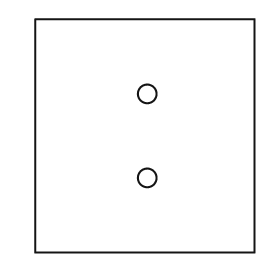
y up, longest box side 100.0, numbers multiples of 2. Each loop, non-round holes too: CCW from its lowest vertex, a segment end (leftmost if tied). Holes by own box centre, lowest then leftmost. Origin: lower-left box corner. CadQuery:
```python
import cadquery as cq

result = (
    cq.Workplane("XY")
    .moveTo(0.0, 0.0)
    .lineTo(94.0, 0.0)
    .lineTo(94.0, 100.0)
    .lineTo(0.0, 100.0)
    .close()
    .moveTo(48.0, 32.0)
    .circle(4.0)
    .moveTo(48.0, 68.0)
    .circle(4.0)
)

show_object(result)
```